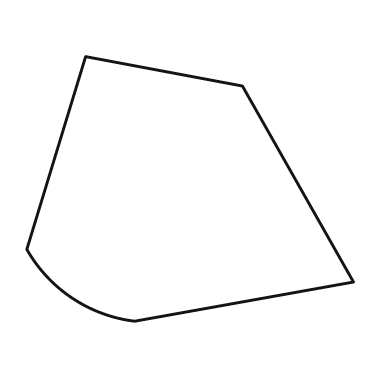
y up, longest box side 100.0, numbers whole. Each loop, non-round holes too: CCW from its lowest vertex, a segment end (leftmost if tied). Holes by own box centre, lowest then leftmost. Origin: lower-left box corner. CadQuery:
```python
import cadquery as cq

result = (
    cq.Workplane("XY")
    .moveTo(33.0, 0.0)
    .lineTo(100.0, 12.0)
    .lineTo(66.0, 72.0)
    .lineTo(18.0, 81.0)
    .lineTo(0.0, 22.0)
    .threePointArc((14.0, 7.0), (33.0, 0.0))
    .close()
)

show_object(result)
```